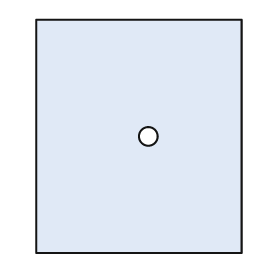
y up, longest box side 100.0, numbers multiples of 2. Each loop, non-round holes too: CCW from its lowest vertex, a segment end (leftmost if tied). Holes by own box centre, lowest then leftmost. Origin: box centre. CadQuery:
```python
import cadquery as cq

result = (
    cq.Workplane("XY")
    .moveTo(-44.0, -50.0)
    .lineTo(44.0, -50.0)
    .lineTo(44.0, 50.0)
    .lineTo(-44.0, 50.0)
    .close()
    .moveTo(4.0, 0.0)
    .circle(4.0)
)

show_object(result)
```